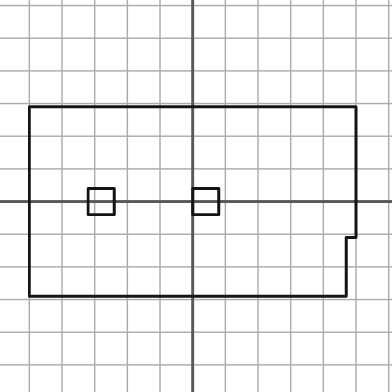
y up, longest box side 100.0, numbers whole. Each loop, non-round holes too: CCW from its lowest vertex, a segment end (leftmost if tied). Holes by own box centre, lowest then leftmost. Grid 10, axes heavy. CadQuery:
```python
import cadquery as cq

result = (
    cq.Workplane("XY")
    .moveTo(-50.0, -29.0)
    .lineTo(47.0, -29.0)
    .lineTo(47.0, -11.0)
    .lineTo(50.0, -11.0)
    .lineTo(50.0, 29.0)
    .lineTo(-50.0, 29.0)
    .close()
    .moveTo(-32.0, -4.0)
    .lineTo(-24.0, -4.0)
    .lineTo(-24.0, 4.0)
    .lineTo(-32.0, 4.0)
    .close()
    .moveTo(0.0, -4.0)
    .lineTo(8.0, -4.0)
    .lineTo(8.0, 4.0)
    .lineTo(0.0, 4.0)
    .close()
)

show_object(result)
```